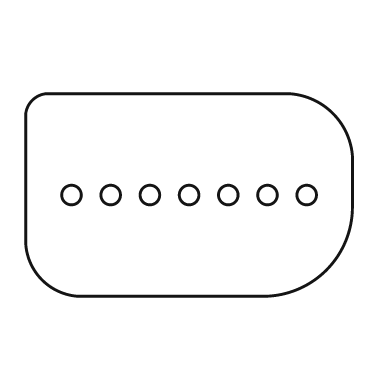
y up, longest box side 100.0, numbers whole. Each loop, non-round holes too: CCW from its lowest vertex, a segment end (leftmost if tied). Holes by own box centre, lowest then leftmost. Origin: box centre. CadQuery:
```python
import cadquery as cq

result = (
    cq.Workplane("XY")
    .moveTo(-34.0, -31.0)
    .lineTo(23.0, -31.0)
    .threePointArc((42.0, -23.0), (50.0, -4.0))
    .lineTo(50.0, 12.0)
    .threePointArc((44.0, 25.0), (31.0, 31.0))
    .lineTo(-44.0, 31.0)
    .threePointArc((-48.0, 29.0), (-50.0, 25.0))
    .lineTo(-50.0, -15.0)
    .threePointArc((-45.0, -26.0), (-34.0, -31.0))
    .close()
    .moveTo(-36.0, 0.0)
    .circle(3.0)
    .moveTo(-24.0, 0.0)
    .circle(3.0)
    .moveTo(-12.0, 0.0)
    .circle(3.0)
    .moveTo(0.0, 0.0)
    .circle(3.0)
    .moveTo(12.0, 0.0)
    .circle(3.0)
    .moveTo(24.0, 0.0)
    .circle(3.0)
    .moveTo(36.0, 0.0)
    .circle(3.0)
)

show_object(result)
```